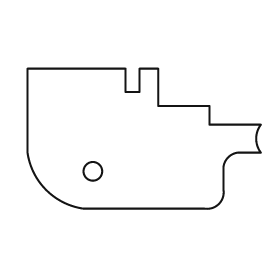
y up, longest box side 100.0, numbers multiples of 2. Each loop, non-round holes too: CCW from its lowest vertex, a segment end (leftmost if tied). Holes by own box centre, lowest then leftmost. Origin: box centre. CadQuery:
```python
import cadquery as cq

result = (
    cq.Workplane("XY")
    .moveTo(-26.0, -30.0)
    .lineTo(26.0, -30.0)
    .threePointArc((32.0, -28.0), (34.0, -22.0))
    .lineTo(34.0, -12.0)
    .threePointArc((36.0, -8.0), (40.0, -6.0))
    .lineTo(50.0, -6.0)
    .threePointArc((48.0, 0.0), (50.0, 6.0))
    .lineTo(28.0, 6.0)
    .lineTo(28.0, 14.0)
    .lineTo(6.0, 14.0)
    .lineTo(6.0, 30.0)
    .lineTo(-2.0, 30.0)
    .lineTo(-2.0, 20.0)
    .lineTo(-8.0, 20.0)
    .lineTo(-8.0, 30.0)
    .lineTo(-50.0, 30.0)
    .lineTo(-50.0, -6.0)
    .threePointArc((-42.0, -22.0), (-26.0, -30.0))
    .close()
    .moveTo(-22.0, -14.0)
    .circle(4.0)
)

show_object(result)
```